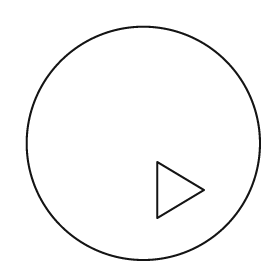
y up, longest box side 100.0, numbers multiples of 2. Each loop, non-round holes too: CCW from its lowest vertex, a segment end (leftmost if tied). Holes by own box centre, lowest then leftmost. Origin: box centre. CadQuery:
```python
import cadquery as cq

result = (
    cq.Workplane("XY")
    .moveTo(0.0, 0.0)
    .circle(50.0)
    .moveTo(6.0, -32.0)
    .lineTo(26.0, -20.0)
    .lineTo(6.0, -8.0)
    .close()
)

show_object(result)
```